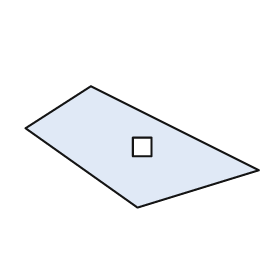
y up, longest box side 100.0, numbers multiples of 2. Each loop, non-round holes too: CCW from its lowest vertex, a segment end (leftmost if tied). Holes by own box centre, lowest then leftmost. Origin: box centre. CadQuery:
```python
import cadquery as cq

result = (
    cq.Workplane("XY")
    .moveTo(-2.0, -26.0)
    .lineTo(50.0, -10.0)
    .lineTo(-22.0, 26.0)
    .lineTo(-50.0, 8.0)
    .close()
    .moveTo(-4.0, -4.0)
    .lineTo(4.0, -4.0)
    .lineTo(4.0, 4.0)
    .lineTo(-4.0, 4.0)
    .close()
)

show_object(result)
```